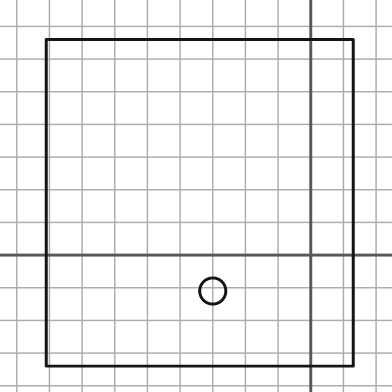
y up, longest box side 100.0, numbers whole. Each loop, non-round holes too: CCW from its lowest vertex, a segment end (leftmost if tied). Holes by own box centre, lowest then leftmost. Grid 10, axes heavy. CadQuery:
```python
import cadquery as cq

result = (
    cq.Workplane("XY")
    .moveTo(-81.0, -34.0)
    .lineTo(13.0, -34.0)
    .lineTo(13.0, 66.0)
    .lineTo(-81.0, 66.0)
    .close()
    .moveTo(-30.0, -11.0)
    .circle(4.0)
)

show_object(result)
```